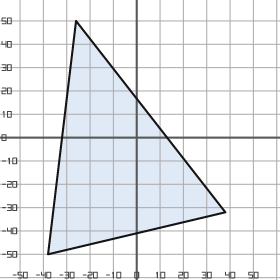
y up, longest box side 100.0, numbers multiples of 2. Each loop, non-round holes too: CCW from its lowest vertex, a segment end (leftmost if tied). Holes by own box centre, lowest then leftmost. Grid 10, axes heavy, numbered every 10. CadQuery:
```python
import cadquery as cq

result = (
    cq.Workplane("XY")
    .moveTo(-38.0, -50.0)
    .lineTo(38.0, -32.0)
    .lineTo(-26.0, 50.0)
    .close()
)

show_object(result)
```